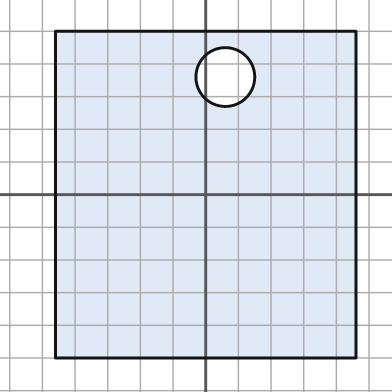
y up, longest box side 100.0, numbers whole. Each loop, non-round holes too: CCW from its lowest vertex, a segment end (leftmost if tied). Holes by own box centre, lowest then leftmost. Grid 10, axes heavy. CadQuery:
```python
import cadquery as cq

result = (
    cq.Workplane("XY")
    .moveTo(-46.0, -50.0)
    .lineTo(46.0, -50.0)
    .lineTo(46.0, 50.0)
    .lineTo(-46.0, 50.0)
    .close()
    .moveTo(6.0, 36.0)
    .circle(9.0)
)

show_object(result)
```